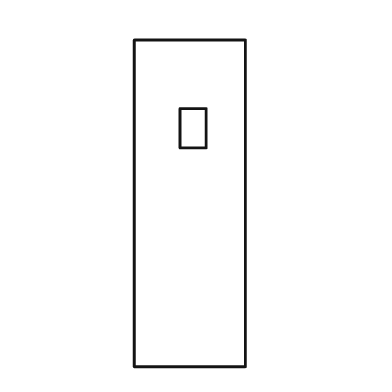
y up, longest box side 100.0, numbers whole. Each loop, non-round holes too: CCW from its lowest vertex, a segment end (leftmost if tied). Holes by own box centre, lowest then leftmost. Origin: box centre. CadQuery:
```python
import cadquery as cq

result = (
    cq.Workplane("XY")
    .moveTo(-17.0, -50.0)
    .lineTo(17.0, -50.0)
    .lineTo(17.0, 50.0)
    .lineTo(-17.0, 50.0)
    .close()
    .moveTo(-3.0, 17.0)
    .lineTo(5.0, 17.0)
    .lineTo(5.0, 29.0)
    .lineTo(-3.0, 29.0)
    .close()
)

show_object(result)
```